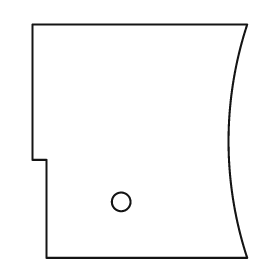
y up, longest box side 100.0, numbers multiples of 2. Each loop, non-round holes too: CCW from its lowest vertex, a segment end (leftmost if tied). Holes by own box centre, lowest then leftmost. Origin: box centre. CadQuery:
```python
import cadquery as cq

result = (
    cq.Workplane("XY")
    .moveTo(-40.0, -50.0)
    .lineTo(46.0, -50.0)
    .threePointArc((38.0, 0.0), (46.0, 50.0))
    .lineTo(-46.0, 50.0)
    .lineTo(-46.0, -8.0)
    .lineTo(-40.0, -8.0)
    .close()
    .moveTo(-8.0, -26.0)
    .circle(4.0)
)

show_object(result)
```